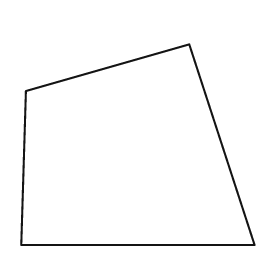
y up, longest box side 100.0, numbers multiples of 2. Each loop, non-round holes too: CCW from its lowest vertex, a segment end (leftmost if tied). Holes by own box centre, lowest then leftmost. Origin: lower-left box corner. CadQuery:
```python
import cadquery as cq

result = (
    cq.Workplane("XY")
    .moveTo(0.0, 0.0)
    .lineTo(100.0, 0.0)
    .lineTo(72.0, 86.0)
    .lineTo(2.0, 66.0)
    .close()
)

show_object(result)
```